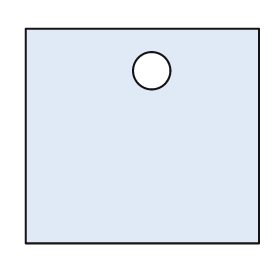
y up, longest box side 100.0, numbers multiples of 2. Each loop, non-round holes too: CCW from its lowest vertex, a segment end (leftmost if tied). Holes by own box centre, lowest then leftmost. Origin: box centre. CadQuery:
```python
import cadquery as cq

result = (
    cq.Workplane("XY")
    .moveTo(-50.0, -46.0)
    .lineTo(50.0, -46.0)
    .lineTo(50.0, 46.0)
    .lineTo(-50.0, 46.0)
    .close()
    .moveTo(4.0, 28.0)
    .circle(8.0)
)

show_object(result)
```